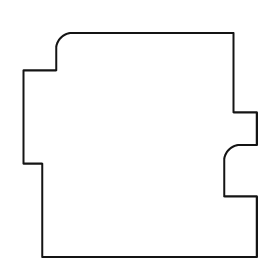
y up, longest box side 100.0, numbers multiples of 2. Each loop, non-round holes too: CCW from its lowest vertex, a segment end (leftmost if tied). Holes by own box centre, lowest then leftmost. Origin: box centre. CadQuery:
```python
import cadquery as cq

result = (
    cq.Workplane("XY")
    .moveTo(-42.0, -48.0)
    .lineTo(50.0, -48.0)
    .lineTo(50.0, -22.0)
    .lineTo(36.0, -22.0)
    .lineTo(36.0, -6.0)
    .threePointArc((38.0, -2.0), (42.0, 0.0))
    .lineTo(50.0, 0.0)
    .lineTo(50.0, 14.0)
    .lineTo(40.0, 14.0)
    .lineTo(40.0, 48.0)
    .lineTo(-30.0, 48.0)
    .threePointArc((-34.0, 46.0), (-36.0, 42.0))
    .lineTo(-36.0, 32.0)
    .lineTo(-50.0, 32.0)
    .lineTo(-50.0, -8.0)
    .lineTo(-42.0, -8.0)
    .close()
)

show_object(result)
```